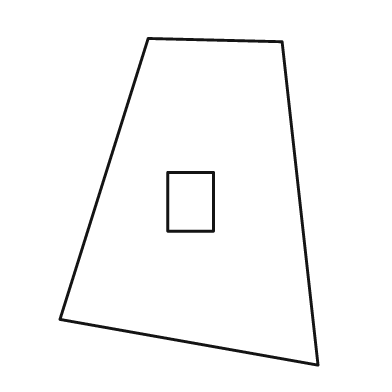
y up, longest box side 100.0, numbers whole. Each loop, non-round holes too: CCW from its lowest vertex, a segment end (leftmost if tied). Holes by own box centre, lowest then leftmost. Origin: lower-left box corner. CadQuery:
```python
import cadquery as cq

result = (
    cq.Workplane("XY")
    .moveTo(79.0, 0.0)
    .lineTo(68.0, 99.0)
    .lineTo(27.0, 100.0)
    .lineTo(0.0, 14.0)
    .close()
    .moveTo(33.0, 41.0)
    .lineTo(47.0, 41.0)
    .lineTo(47.0, 59.0)
    .lineTo(33.0, 59.0)
    .close()
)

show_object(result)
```